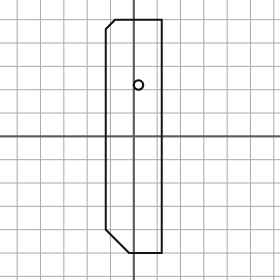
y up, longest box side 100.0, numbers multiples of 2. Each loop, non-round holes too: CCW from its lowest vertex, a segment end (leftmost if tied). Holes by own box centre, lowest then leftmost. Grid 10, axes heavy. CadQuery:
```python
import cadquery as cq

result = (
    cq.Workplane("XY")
    .moveTo(-2.0, -50.0)
    .lineTo(12.0, -50.0)
    .lineTo(12.0, 50.0)
    .lineTo(-8.0, 50.0)
    .lineTo(-12.0, 46.0)
    .lineTo(-12.0, -40.0)
    .close()
    .moveTo(2.0, 22.0)
    .circle(2.0)
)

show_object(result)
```